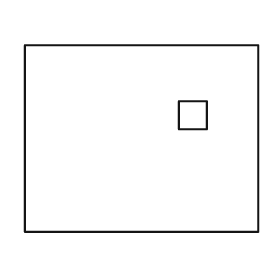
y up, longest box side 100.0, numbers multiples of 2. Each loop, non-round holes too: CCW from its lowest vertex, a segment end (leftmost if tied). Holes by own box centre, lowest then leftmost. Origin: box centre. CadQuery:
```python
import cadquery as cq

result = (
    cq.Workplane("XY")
    .moveTo(-50.0, -40.0)
    .lineTo(50.0, -40.0)
    .lineTo(50.0, 40.0)
    .lineTo(-50.0, 40.0)
    .close()
    .moveTo(16.0, 4.0)
    .lineTo(28.0, 4.0)
    .lineTo(28.0, 16.0)
    .lineTo(16.0, 16.0)
    .close()
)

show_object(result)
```